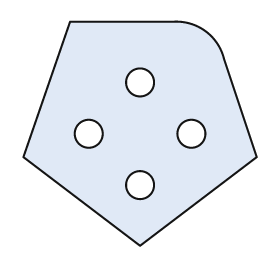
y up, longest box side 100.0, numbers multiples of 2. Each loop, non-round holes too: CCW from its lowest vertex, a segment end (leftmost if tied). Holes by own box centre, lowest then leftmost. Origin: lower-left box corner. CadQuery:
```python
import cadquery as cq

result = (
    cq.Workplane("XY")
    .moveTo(50.0, 0.0)
    .lineTo(100.0, 38.0)
    .lineTo(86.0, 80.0)
    .threePointArc((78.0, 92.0), (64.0, 96.0))
    .lineTo(20.0, 96.0)
    .lineTo(0.0, 38.0)
    .close()
    .moveTo(50.0, 26.0)
    .circle(6.0)
    .moveTo(28.0, 48.0)
    .circle(6.0)
    .moveTo(72.0, 48.0)
    .circle(6.0)
    .moveTo(50.0, 70.0)
    .circle(6.0)
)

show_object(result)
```